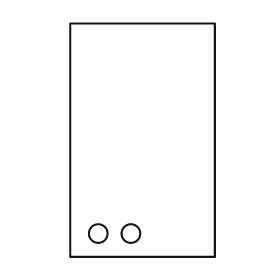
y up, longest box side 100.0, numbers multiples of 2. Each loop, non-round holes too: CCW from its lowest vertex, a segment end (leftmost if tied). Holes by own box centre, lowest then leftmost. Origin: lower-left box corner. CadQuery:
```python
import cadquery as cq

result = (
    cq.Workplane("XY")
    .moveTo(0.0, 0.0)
    .lineTo(62.0, 0.0)
    .lineTo(62.0, 100.0)
    .lineTo(0.0, 100.0)
    .close()
    .moveTo(12.0, 10.0)
    .circle(4.0)
    .moveTo(26.0, 10.0)
    .circle(4.0)
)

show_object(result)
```